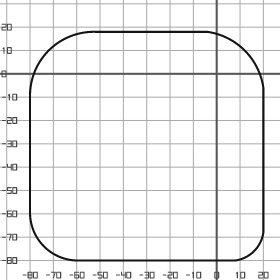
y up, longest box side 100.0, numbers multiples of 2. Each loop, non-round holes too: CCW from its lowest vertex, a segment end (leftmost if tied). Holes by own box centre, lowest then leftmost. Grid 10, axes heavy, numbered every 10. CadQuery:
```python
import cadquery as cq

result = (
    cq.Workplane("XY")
    .moveTo(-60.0, -80.0)
    .lineTo(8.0, -80.0)
    .threePointArc((16.0, -76.0), (20.0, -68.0))
    .lineTo(20.0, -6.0)
    .threePointArc((12.0, 10.0), (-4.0, 18.0))
    .lineTo(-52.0, 18.0)
    .threePointArc((-72.0, 10.0), (-80.0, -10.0))
    .lineTo(-80.0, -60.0)
    .threePointArc((-74.0, -74.0), (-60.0, -80.0))
    .close()
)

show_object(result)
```